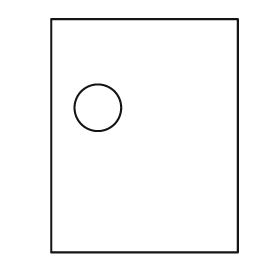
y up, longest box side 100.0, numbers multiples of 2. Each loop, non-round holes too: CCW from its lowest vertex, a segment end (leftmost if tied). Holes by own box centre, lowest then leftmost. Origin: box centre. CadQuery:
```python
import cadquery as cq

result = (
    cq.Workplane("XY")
    .moveTo(-40.0, -50.0)
    .lineTo(40.0, -50.0)
    .lineTo(40.0, 50.0)
    .lineTo(-40.0, 50.0)
    .close()
    .moveTo(-20.0, 12.0)
    .circle(10.0)
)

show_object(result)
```